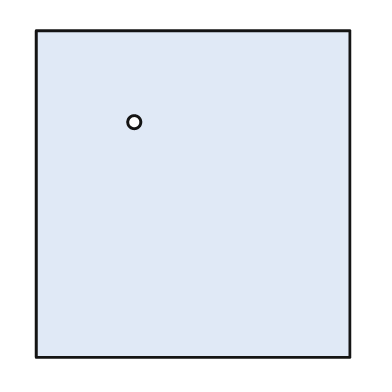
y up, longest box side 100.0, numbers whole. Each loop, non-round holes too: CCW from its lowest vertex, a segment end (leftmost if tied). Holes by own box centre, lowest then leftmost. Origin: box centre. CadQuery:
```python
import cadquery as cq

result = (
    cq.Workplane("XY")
    .moveTo(-48.0, -50.0)
    .lineTo(48.0, -50.0)
    .lineTo(48.0, 50.0)
    .lineTo(-48.0, 50.0)
    .close()
    .moveTo(-18.0, 22.0)
    .circle(2.0)
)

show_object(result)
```